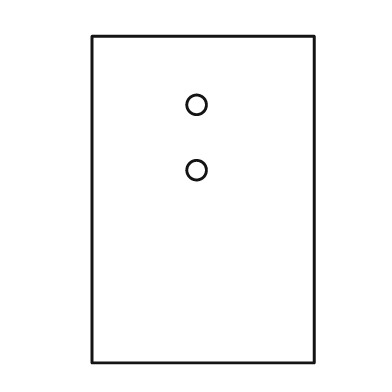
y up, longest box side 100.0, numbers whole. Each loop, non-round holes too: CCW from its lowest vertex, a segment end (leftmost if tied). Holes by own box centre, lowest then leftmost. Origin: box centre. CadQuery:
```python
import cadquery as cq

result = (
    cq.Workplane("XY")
    .moveTo(-34.0, -50.0)
    .lineTo(34.0, -50.0)
    .lineTo(34.0, 50.0)
    .lineTo(-34.0, 50.0)
    .close()
    .moveTo(-2.0, 9.0)
    .circle(3.0)
    .moveTo(-2.0, 29.0)
    .circle(3.0)
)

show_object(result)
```